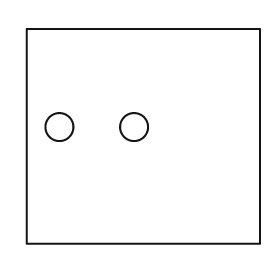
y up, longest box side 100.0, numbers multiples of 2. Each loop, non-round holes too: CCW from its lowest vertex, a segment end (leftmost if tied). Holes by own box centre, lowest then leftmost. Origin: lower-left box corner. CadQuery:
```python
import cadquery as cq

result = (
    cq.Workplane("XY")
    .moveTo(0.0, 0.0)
    .lineTo(100.0, 0.0)
    .lineTo(100.0, 92.0)
    .lineTo(0.0, 92.0)
    .close()
    .moveTo(14.0, 50.0)
    .circle(6.0)
    .moveTo(46.0, 50.0)
    .circle(6.0)
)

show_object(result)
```